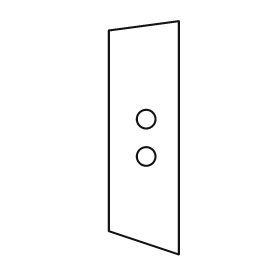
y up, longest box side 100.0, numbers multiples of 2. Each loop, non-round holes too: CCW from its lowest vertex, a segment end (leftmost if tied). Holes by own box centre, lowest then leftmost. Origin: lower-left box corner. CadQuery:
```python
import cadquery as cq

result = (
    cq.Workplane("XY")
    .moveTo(30.0, 0.0)
    .lineTo(30.0, 100.0)
    .lineTo(0.0, 96.0)
    .lineTo(0.0, 10.0)
    .close()
    .moveTo(16.0, 42.0)
    .circle(4.0)
    .moveTo(16.0, 58.0)
    .circle(4.0)
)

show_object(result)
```